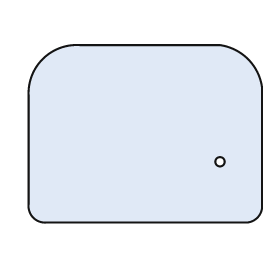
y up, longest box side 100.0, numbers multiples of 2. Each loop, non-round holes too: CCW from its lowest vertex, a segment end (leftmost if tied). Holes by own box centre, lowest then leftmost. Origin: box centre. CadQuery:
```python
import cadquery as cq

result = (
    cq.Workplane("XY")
    .moveTo(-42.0, -38.0)
    .lineTo(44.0, -38.0)
    .threePointArc((48.0, -36.0), (50.0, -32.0))
    .lineTo(50.0, 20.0)
    .threePointArc((44.0, 32.0), (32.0, 38.0))
    .lineTo(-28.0, 38.0)
    .threePointArc((-44.0, 32.0), (-50.0, 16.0))
    .lineTo(-50.0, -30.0)
    .threePointArc((-48.0, -36.0), (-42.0, -38.0))
    .close()
    .moveTo(32.0, -12.0)
    .circle(2.0)
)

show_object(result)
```